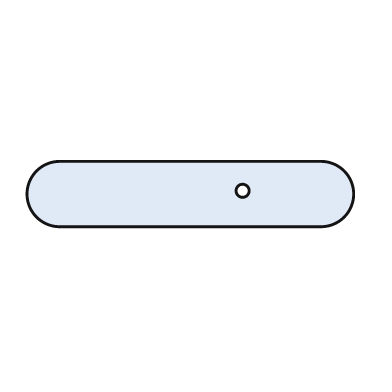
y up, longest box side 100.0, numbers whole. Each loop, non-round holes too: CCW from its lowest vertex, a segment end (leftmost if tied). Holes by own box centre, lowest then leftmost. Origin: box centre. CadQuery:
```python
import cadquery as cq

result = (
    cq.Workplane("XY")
    .moveTo(-40.0, -10.0)
    .lineTo(40.0, -10.0)
    .threePointArc((50.0, 0.0), (40.0, 10.0))
    .lineTo(-40.0, 10.0)
    .threePointArc((-50.0, 0.0), (-40.0, -10.0))
    .close()
    .moveTo(16.0, 1.0)
    .circle(2.0)
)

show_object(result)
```